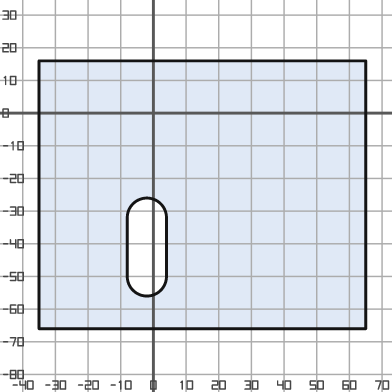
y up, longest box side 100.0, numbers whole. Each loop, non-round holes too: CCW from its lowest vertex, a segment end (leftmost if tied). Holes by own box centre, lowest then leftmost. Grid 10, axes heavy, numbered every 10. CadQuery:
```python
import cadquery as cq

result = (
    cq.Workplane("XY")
    .moveTo(-35.0, -66.0)
    .lineTo(65.0, -66.0)
    .lineTo(65.0, 16.0)
    .lineTo(-35.0, 16.0)
    .close()
    .moveTo(-8.0, -50.0)
    .threePointArc((-2.0, -56.0), (4.0, -50.0))
    .lineTo(4.0, -32.0)
    .threePointArc((-2.0, -26.0), (-8.0, -32.0))
    .close()
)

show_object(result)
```